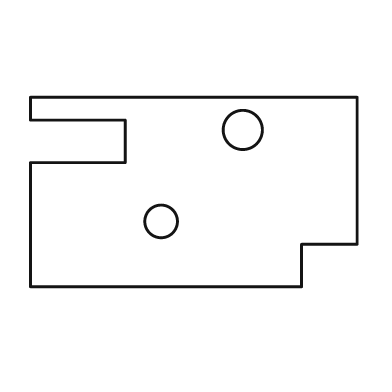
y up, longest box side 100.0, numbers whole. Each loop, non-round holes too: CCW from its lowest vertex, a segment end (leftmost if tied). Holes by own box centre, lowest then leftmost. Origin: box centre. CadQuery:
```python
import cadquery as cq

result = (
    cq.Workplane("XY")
    .moveTo(-50.0, -29.0)
    .lineTo(33.0, -29.0)
    .lineTo(33.0, -16.0)
    .lineTo(50.0, -16.0)
    .lineTo(50.0, 29.0)
    .lineTo(-50.0, 29.0)
    .lineTo(-50.0, 22.0)
    .lineTo(-21.0, 22.0)
    .lineTo(-21.0, 9.0)
    .lineTo(-50.0, 9.0)
    .close()
    .moveTo(-10.0, -9.0)
    .circle(5.0)
    .moveTo(15.0, 19.0)
    .circle(6.0)
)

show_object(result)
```